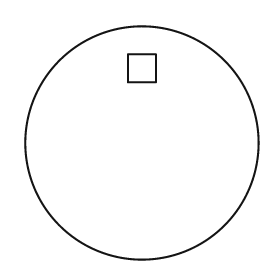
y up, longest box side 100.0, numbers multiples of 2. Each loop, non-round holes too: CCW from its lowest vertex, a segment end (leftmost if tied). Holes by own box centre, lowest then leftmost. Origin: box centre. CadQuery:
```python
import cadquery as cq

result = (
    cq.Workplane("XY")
    .moveTo(0.0, 0.0)
    .circle(50.0)
    .moveTo(-6.0, 26.0)
    .lineTo(6.0, 26.0)
    .lineTo(6.0, 38.0)
    .lineTo(-6.0, 38.0)
    .close()
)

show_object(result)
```